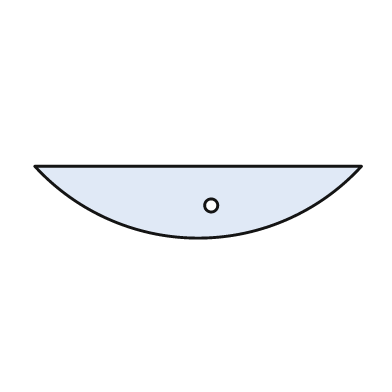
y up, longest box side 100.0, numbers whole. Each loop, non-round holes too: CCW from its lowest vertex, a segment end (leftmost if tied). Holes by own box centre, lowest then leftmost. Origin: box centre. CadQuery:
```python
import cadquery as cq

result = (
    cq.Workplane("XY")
    .moveTo(-50.0, 11.0)
    .threePointArc((0.0, -11.0), (50.0, 11.0))
    .close()
    .moveTo(4.0, -1.0)
    .circle(2.0)
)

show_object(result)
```